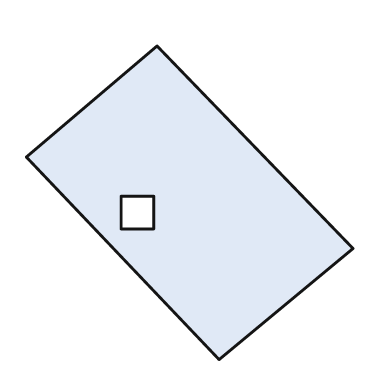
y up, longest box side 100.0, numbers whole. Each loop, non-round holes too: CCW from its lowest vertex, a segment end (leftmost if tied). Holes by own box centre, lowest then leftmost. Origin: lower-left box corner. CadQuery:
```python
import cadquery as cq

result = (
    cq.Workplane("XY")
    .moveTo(59.0, 0.0)
    .lineTo(100.0, 34.0)
    .lineTo(40.0, 96.0)
    .lineTo(0.0, 62.0)
    .close()
    .moveTo(29.0, 40.0)
    .lineTo(39.0, 40.0)
    .lineTo(39.0, 50.0)
    .lineTo(29.0, 50.0)
    .close()
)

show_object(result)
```